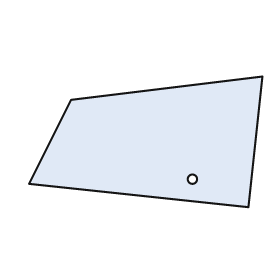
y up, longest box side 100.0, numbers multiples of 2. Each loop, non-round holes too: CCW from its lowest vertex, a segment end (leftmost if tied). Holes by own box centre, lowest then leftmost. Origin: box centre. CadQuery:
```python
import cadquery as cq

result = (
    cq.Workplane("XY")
    .moveTo(44.0, -28.0)
    .lineTo(50.0, 28.0)
    .lineTo(-32.0, 18.0)
    .lineTo(-50.0, -18.0)
    .close()
    .moveTo(20.0, -16.0)
    .circle(2.0)
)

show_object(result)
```